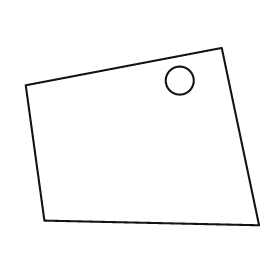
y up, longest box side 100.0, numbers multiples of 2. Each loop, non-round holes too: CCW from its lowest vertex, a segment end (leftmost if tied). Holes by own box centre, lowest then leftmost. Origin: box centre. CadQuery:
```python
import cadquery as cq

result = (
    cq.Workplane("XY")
    .moveTo(50.0, -38.0)
    .lineTo(34.0, 38.0)
    .lineTo(-50.0, 22.0)
    .lineTo(-42.0, -36.0)
    .close()
    .moveTo(16.0, 24.0)
    .circle(6.0)
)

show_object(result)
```